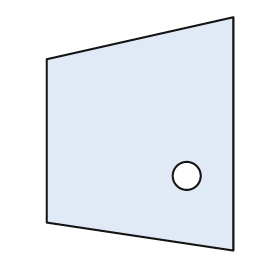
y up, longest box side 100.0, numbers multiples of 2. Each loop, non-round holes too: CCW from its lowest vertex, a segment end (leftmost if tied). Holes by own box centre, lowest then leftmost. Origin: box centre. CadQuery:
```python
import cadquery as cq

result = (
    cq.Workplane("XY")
    .moveTo(40.0, -50.0)
    .lineTo(40.0, 50.0)
    .lineTo(-40.0, 32.0)
    .lineTo(-40.0, -38.0)
    .close()
    .moveTo(20.0, -18.0)
    .circle(6.0)
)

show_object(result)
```